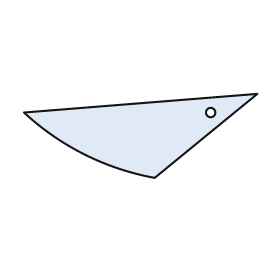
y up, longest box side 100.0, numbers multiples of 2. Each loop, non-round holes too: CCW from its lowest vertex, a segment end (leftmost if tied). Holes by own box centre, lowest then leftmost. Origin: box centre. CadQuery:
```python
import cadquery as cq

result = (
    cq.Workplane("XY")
    .moveTo(6.0, -18.0)
    .lineTo(50.0, 18.0)
    .lineTo(-50.0, 10.0)
    .threePointArc((-24.0, -8.0), (6.0, -18.0))
    .close()
    .moveTo(30.0, 10.0)
    .circle(2.0)
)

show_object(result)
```